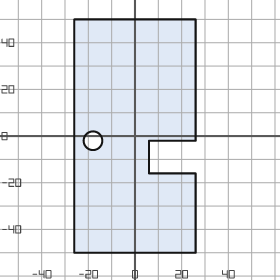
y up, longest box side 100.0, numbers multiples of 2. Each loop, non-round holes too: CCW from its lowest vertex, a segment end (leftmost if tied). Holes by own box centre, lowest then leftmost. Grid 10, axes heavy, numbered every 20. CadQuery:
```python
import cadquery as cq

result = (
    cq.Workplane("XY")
    .moveTo(-26.0, -50.0)
    .lineTo(26.0, -50.0)
    .lineTo(26.0, -16.0)
    .lineTo(6.0, -16.0)
    .lineTo(6.0, -2.0)
    .lineTo(26.0, -2.0)
    .lineTo(26.0, 50.0)
    .lineTo(-26.0, 50.0)
    .close()
    .moveTo(-18.0, -2.0)
    .circle(4.0)
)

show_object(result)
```